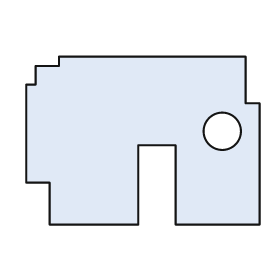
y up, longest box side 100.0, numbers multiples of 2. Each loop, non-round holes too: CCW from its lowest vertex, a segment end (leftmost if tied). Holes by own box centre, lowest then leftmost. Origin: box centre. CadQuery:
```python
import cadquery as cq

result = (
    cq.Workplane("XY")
    .moveTo(-40.0, -36.0)
    .lineTo(-2.0, -36.0)
    .lineTo(-2.0, -2.0)
    .lineTo(14.0, -2.0)
    .lineTo(14.0, -36.0)
    .lineTo(50.0, -36.0)
    .lineTo(50.0, 16.0)
    .lineTo(44.0, 16.0)
    .lineTo(44.0, 36.0)
    .lineTo(-36.0, 36.0)
    .lineTo(-36.0, 32.0)
    .lineTo(-46.0, 32.0)
    .lineTo(-46.0, 24.0)
    .lineTo(-50.0, 24.0)
    .lineTo(-50.0, -18.0)
    .lineTo(-40.0, -18.0)
    .close()
    .moveTo(34.0, 4.0)
    .circle(8.0)
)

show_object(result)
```